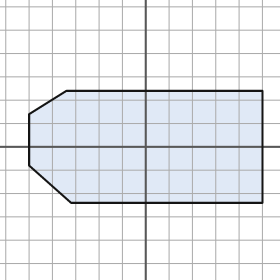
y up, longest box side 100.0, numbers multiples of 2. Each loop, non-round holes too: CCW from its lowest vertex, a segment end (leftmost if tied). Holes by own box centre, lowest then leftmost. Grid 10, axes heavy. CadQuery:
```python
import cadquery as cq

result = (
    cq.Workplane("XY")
    .moveTo(-32.0, -24.0)
    .lineTo(50.0, -24.0)
    .lineTo(50.0, 24.0)
    .lineTo(-34.0, 24.0)
    .lineTo(-50.0, 14.0)
    .lineTo(-50.0, -8.0)
    .close()
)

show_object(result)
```